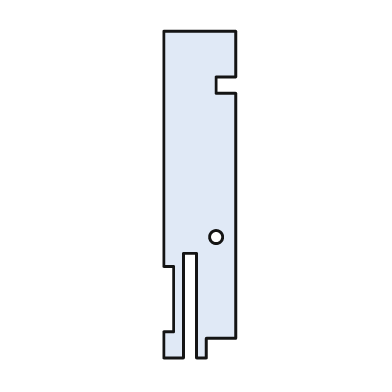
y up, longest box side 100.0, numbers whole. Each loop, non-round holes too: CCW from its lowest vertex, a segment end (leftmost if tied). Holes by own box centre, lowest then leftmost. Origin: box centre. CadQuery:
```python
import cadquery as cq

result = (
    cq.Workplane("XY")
    .moveTo(-11.0, -50.0)
    .lineTo(-5.0, -50.0)
    .lineTo(-5.0, -18.0)
    .lineTo(-1.0, -18.0)
    .lineTo(-1.0, -50.0)
    .lineTo(2.0, -50.0)
    .lineTo(2.0, -44.0)
    .lineTo(11.0, -44.0)
    .lineTo(11.0, 31.0)
    .lineTo(5.0, 31.0)
    .lineTo(5.0, 36.0)
    .lineTo(11.0, 36.0)
    .lineTo(11.0, 50.0)
    .lineTo(-11.0, 50.0)
    .lineTo(-11.0, -22.0)
    .lineTo(-8.0, -22.0)
    .lineTo(-8.0, -42.0)
    .lineTo(-11.0, -42.0)
    .close()
    .moveTo(5.0, -13.0)
    .circle(2.0)
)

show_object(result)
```